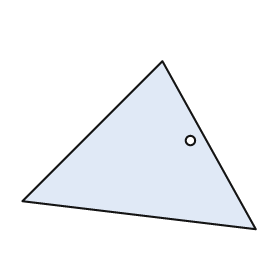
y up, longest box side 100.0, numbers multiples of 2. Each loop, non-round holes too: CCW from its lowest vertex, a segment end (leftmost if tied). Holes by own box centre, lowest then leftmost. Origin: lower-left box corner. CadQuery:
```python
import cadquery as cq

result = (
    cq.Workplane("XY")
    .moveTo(100.0, 0.0)
    .lineTo(60.0, 72.0)
    .lineTo(0.0, 12.0)
    .close()
    .moveTo(72.0, 38.0)
    .circle(2.0)
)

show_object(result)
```